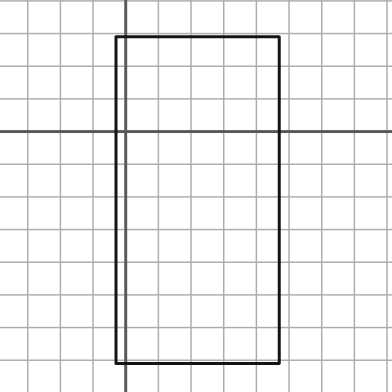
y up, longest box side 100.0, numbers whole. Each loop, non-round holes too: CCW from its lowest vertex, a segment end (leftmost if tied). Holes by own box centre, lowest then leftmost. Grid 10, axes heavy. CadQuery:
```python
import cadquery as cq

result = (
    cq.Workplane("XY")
    .moveTo(-3.0, -71.0)
    .lineTo(47.0, -71.0)
    .lineTo(47.0, 29.0)
    .lineTo(-3.0, 29.0)
    .close()
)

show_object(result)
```